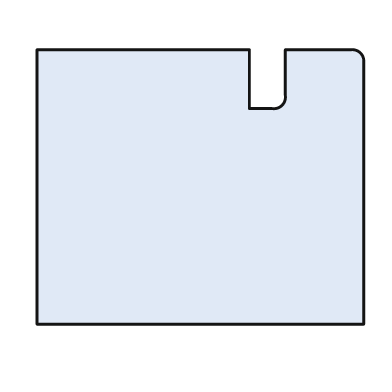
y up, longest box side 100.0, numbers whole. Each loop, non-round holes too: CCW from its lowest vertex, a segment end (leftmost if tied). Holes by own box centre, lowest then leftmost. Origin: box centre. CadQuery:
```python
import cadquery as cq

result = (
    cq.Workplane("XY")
    .moveTo(-50.0, -42.0)
    .lineTo(50.0, -42.0)
    .lineTo(50.0, 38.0)
    .threePointArc((49.0, 41.0), (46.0, 42.0))
    .lineTo(26.0, 42.0)
    .lineTo(26.0, 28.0)
    .threePointArc((25.0, 25.0), (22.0, 24.0))
    .lineTo(15.0, 24.0)
    .lineTo(15.0, 42.0)
    .lineTo(-50.0, 42.0)
    .close()
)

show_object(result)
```